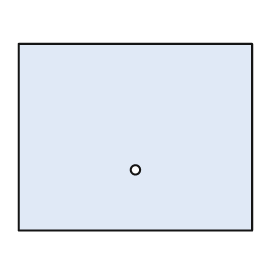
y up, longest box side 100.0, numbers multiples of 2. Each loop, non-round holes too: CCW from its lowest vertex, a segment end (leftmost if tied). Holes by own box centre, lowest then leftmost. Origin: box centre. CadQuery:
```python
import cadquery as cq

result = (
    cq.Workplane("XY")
    .moveTo(-50.0, -40.0)
    .lineTo(50.0, -40.0)
    .lineTo(50.0, 40.0)
    .lineTo(-50.0, 40.0)
    .close()
    .moveTo(0.0, -14.0)
    .circle(2.0)
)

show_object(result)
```